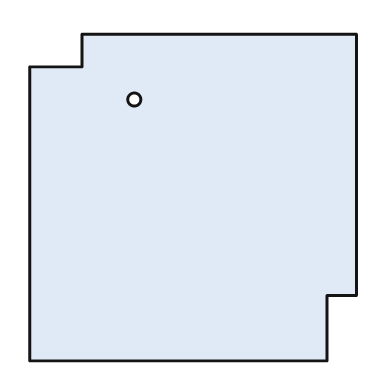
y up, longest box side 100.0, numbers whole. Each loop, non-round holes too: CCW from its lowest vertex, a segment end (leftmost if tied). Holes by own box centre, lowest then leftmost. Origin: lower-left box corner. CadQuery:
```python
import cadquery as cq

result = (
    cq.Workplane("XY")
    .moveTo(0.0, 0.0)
    .lineTo(91.0, 0.0)
    .lineTo(91.0, 20.0)
    .lineTo(100.0, 20.0)
    .lineTo(100.0, 100.0)
    .lineTo(16.0, 100.0)
    .lineTo(16.0, 90.0)
    .lineTo(0.0, 90.0)
    .close()
    .moveTo(32.0, 80.0)
    .circle(2.0)
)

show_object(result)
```